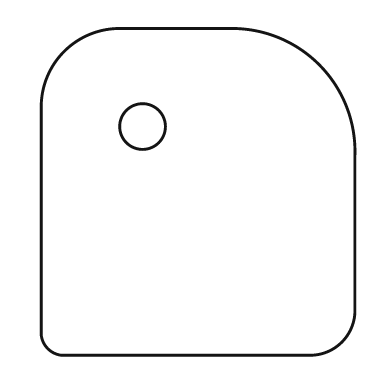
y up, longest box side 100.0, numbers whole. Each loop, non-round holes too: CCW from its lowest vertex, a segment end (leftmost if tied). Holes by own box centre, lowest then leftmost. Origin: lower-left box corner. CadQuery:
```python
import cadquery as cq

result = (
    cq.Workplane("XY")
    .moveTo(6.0, 0.0)
    .lineTo(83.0, 0.0)
    .threePointArc((92.0, 4.0), (96.0, 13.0))
    .lineTo(96.0, 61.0)
    .threePointArc((85.0, 89.0), (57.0, 100.0))
    .lineTo(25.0, 100.0)
    .threePointArc((7.0, 93.0), (0.0, 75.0))
    .lineTo(0.0, 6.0)
    .threePointArc((2.0, 2.0), (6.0, 0.0))
    .close()
    .moveTo(31.0, 70.0)
    .circle(7.0)
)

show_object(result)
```